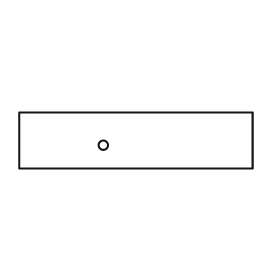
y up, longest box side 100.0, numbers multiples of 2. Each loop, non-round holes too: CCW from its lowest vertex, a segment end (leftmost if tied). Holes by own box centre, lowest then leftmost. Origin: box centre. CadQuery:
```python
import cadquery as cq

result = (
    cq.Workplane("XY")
    .moveTo(-50.0, -12.0)
    .lineTo(50.0, -12.0)
    .lineTo(50.0, 12.0)
    .lineTo(-50.0, 12.0)
    .close()
    .moveTo(-14.0, -2.0)
    .circle(2.0)
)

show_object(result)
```